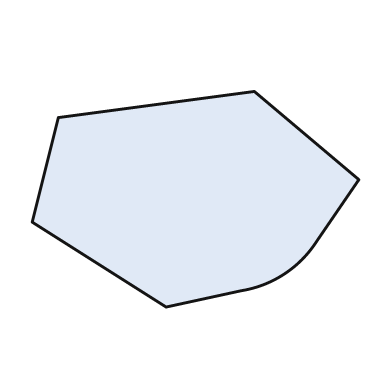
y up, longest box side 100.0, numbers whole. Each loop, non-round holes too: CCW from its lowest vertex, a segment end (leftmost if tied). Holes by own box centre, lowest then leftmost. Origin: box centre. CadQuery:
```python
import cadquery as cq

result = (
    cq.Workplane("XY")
    .moveTo(-9.0, -33.0)
    .lineTo(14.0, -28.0)
    .threePointArc((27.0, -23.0), (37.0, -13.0))
    .lineTo(50.0, 6.0)
    .lineTo(18.0, 33.0)
    .lineTo(-42.0, 25.0)
    .lineTo(-50.0, -7.0)
    .close()
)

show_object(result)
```